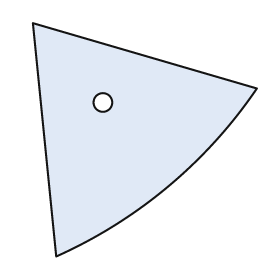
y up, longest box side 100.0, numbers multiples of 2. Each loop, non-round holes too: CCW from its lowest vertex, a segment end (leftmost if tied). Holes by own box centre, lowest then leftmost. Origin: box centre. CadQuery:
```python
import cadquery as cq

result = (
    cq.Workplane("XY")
    .moveTo(-38.0, -50.0)
    .threePointArc((10.0, -20.0), (48.0, 22.0))
    .lineTo(-48.0, 50.0)
    .close()
    .moveTo(-18.0, 16.0)
    .circle(4.0)
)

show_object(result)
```